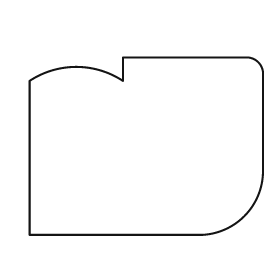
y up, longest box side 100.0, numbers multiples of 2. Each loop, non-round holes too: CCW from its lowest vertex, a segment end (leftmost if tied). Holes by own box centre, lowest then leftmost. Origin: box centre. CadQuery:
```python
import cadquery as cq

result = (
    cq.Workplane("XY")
    .moveTo(-50.0, -38.0)
    .lineTo(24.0, -38.0)
    .threePointArc((42.0, -30.0), (50.0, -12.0))
    .lineTo(50.0, 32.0)
    .threePointArc((48.0, 36.0), (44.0, 38.0))
    .lineTo(-10.0, 38.0)
    .lineTo(-10.0, 28.0)
    .threePointArc((-30.0, 34.0), (-50.0, 28.0))
    .close()
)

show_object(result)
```